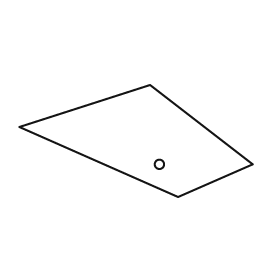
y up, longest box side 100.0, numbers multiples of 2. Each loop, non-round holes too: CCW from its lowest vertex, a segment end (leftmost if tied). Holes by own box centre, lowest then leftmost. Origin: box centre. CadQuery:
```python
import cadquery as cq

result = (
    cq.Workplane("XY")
    .moveTo(18.0, -24.0)
    .lineTo(50.0, -10.0)
    .lineTo(6.0, 24.0)
    .lineTo(-50.0, 6.0)
    .close()
    .moveTo(10.0, -10.0)
    .circle(2.0)
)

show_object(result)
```